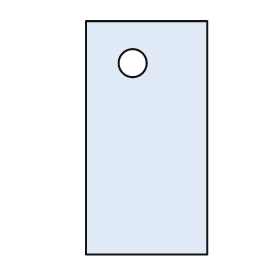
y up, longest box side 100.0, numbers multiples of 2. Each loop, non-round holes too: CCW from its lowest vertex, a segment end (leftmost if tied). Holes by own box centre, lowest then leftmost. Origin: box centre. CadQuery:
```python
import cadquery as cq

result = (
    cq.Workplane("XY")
    .moveTo(-26.0, -50.0)
    .lineTo(26.0, -50.0)
    .lineTo(26.0, 50.0)
    .lineTo(-26.0, 50.0)
    .close()
    .moveTo(-6.0, 32.0)
    .circle(6.0)
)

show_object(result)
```